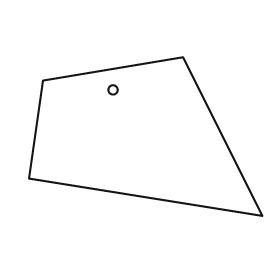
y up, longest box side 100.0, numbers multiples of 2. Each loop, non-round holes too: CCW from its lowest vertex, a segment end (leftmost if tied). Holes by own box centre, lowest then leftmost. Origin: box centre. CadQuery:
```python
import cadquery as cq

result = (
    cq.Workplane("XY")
    .moveTo(50.0, -34.0)
    .lineTo(16.0, 34.0)
    .lineTo(-44.0, 24.0)
    .lineTo(-50.0, -18.0)
    .close()
    .moveTo(-14.0, 20.0)
    .circle(2.0)
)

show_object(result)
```